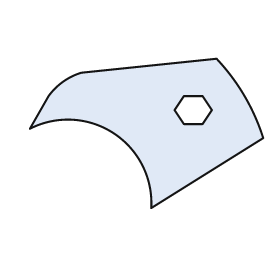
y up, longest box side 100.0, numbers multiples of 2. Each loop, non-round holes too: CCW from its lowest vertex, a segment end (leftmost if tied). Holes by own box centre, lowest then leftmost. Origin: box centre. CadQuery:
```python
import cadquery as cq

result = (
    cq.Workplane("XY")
    .moveTo(2.0, -32.0)
    .lineTo(50.0, -2.0)
    .threePointArc((42.0, 16.0), (30.0, 32.0))
    .lineTo(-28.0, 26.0)
    .threePointArc((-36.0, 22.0), (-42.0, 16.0))
    .lineTo(-50.0, 2.0)
    .threePointArc((-14.0, 0.0), (2.0, -32.0))
    .close()
    .moveTo(16.0, 4.0)
    .lineTo(24.0, 4.0)
    .lineTo(28.0, 10.0)
    .lineTo(24.0, 16.0)
    .lineTo(16.0, 16.0)
    .lineTo(12.0, 10.0)
    .close()
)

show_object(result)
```